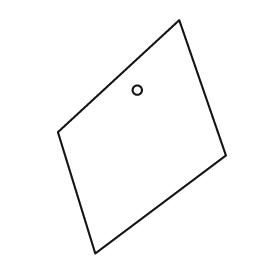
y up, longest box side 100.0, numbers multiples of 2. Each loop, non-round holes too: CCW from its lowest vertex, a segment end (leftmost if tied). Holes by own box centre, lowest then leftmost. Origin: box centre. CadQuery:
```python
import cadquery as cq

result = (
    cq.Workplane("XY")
    .moveTo(-20.0, -50.0)
    .lineTo(36.0, -8.0)
    .lineTo(16.0, 50.0)
    .lineTo(-36.0, 2.0)
    .close()
    .moveTo(-2.0, 20.0)
    .circle(2.0)
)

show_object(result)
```